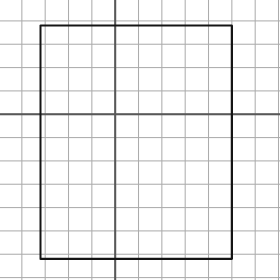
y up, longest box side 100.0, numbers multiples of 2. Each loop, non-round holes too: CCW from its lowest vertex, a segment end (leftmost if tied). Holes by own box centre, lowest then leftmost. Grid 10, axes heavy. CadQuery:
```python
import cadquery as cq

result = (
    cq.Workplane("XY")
    .moveTo(-32.0, -62.0)
    .lineTo(50.0, -62.0)
    .lineTo(50.0, 38.0)
    .lineTo(-32.0, 38.0)
    .close()
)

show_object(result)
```